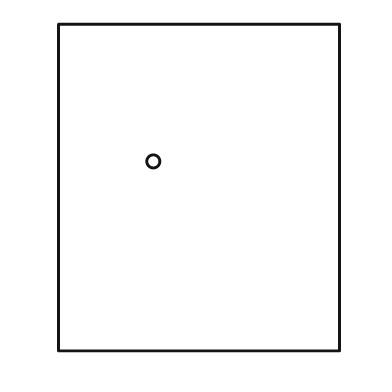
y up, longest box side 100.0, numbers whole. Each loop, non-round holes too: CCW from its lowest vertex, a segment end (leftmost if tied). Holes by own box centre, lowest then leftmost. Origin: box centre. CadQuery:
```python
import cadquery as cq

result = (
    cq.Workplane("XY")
    .moveTo(-43.0, -50.0)
    .lineTo(43.0, -50.0)
    .lineTo(43.0, 50.0)
    .lineTo(-43.0, 50.0)
    .close()
    .moveTo(-14.0, 8.0)
    .circle(2.0)
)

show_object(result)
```